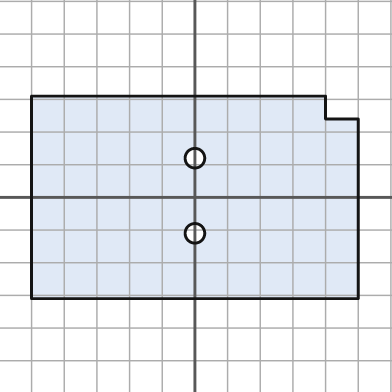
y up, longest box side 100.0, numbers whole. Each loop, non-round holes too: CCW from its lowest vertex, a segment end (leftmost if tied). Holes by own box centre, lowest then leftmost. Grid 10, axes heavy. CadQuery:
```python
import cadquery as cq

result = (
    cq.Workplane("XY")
    .moveTo(-50.0, -31.0)
    .lineTo(50.0, -31.0)
    .lineTo(50.0, 24.0)
    .lineTo(40.0, 24.0)
    .lineTo(40.0, 31.0)
    .lineTo(-50.0, 31.0)
    .close()
    .moveTo(0.0, -11.0)
    .circle(3.0)
    .moveTo(0.0, 12.0)
    .circle(3.0)
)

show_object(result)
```